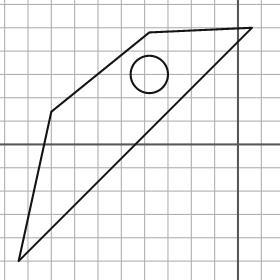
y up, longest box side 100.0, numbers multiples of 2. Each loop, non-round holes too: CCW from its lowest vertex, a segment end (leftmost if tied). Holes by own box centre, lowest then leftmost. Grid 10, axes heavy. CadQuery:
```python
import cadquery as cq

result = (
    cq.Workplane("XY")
    .moveTo(-94.0, -50.0)
    .lineTo(6.0, 50.0)
    .lineTo(-38.0, 48.0)
    .lineTo(-80.0, 14.0)
    .close()
    .moveTo(-38.0, 30.0)
    .circle(8.0)
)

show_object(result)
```